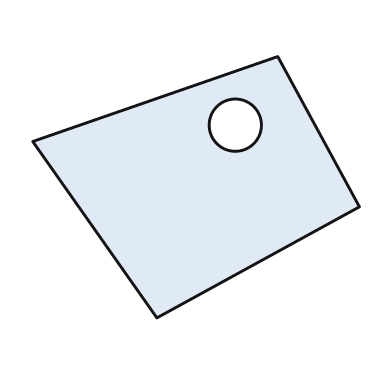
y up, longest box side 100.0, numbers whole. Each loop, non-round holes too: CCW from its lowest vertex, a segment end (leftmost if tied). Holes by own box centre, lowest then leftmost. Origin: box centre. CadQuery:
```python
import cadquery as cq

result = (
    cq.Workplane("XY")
    .moveTo(-12.0, -40.0)
    .lineTo(50.0, -6.0)
    .lineTo(25.0, 40.0)
    .lineTo(-50.0, 14.0)
    .close()
    .moveTo(12.0, 19.0)
    .circle(8.0)
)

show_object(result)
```